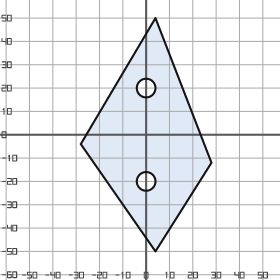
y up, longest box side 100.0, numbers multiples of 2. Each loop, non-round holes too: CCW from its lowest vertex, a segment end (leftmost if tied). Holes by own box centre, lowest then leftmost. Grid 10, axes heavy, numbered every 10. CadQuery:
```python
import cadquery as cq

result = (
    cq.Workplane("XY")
    .moveTo(4.0, -50.0)
    .lineTo(28.0, -12.0)
    .lineTo(4.0, 50.0)
    .lineTo(-28.0, -4.0)
    .close()
    .moveTo(0.0, -20.0)
    .circle(4.0)
    .moveTo(0.0, 20.0)
    .circle(4.0)
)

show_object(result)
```